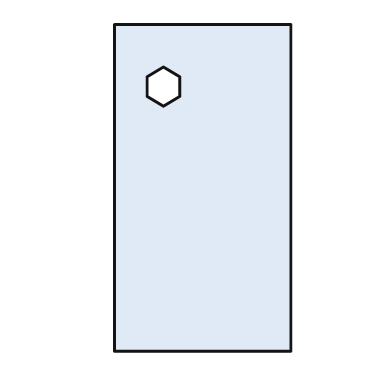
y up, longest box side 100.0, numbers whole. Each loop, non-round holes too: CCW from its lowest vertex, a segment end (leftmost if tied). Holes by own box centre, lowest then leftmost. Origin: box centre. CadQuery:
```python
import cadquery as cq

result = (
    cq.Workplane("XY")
    .moveTo(-27.0, -50.0)
    .lineTo(27.0, -50.0)
    .lineTo(27.0, 50.0)
    .lineTo(-27.0, 50.0)
    .close()
    .moveTo(-12.0, 25.0)
    .lineTo(-7.0, 28.0)
    .lineTo(-7.0, 34.0)
    .lineTo(-12.0, 37.0)
    .lineTo(-17.0, 34.0)
    .lineTo(-17.0, 28.0)
    .close()
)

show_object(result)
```